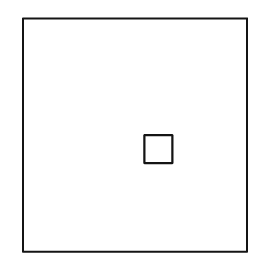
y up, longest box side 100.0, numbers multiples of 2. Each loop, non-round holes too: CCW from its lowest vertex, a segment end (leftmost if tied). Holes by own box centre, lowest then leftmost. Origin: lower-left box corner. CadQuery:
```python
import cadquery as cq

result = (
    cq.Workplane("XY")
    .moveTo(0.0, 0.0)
    .lineTo(96.0, 0.0)
    .lineTo(96.0, 100.0)
    .lineTo(0.0, 100.0)
    .close()
    .moveTo(52.0, 38.0)
    .lineTo(64.0, 38.0)
    .lineTo(64.0, 50.0)
    .lineTo(52.0, 50.0)
    .close()
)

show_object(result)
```